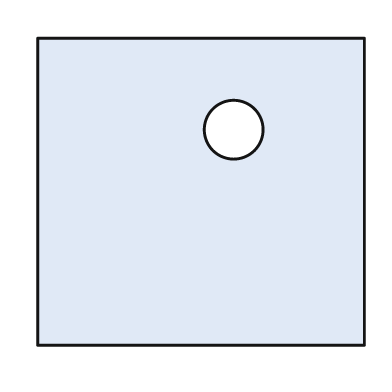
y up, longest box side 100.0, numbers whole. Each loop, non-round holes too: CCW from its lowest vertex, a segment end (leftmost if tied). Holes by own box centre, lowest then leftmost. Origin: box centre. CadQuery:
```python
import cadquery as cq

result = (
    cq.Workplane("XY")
    .moveTo(-50.0, -47.0)
    .lineTo(50.0, -47.0)
    .lineTo(50.0, 47.0)
    .lineTo(-50.0, 47.0)
    .close()
    .moveTo(10.0, 19.0)
    .circle(9.0)
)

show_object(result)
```